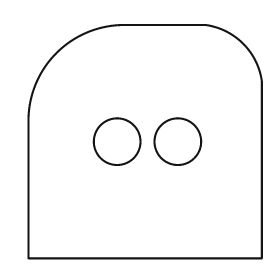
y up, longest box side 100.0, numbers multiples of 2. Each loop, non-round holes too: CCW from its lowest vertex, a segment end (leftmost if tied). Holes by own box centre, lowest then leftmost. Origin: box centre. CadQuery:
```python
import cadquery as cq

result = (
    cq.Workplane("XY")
    .moveTo(-50.0, -50.0)
    .lineTo(50.0, -50.0)
    .lineTo(50.0, 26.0)
    .threePointArc((42.0, 42.0), (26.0, 50.0))
    .lineTo(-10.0, 50.0)
    .threePointArc((-38.0, 38.0), (-50.0, 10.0))
    .close()
    .moveTo(-12.0, 0.0)
    .circle(10.0)
    .moveTo(14.0, 0.0)
    .circle(10.0)
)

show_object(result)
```